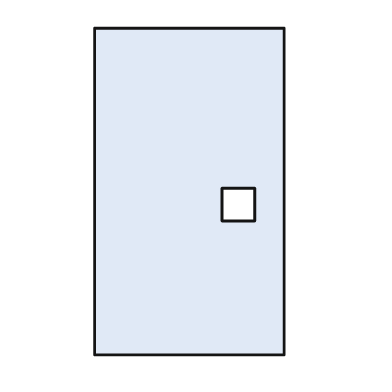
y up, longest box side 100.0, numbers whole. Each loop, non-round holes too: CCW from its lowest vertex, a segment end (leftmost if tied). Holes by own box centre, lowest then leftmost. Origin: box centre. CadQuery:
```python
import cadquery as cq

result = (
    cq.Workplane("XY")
    .moveTo(-29.0, -50.0)
    .lineTo(29.0, -50.0)
    .lineTo(29.0, 50.0)
    .lineTo(-29.0, 50.0)
    .close()
    .moveTo(10.0, -9.0)
    .lineTo(20.0, -9.0)
    .lineTo(20.0, 1.0)
    .lineTo(10.0, 1.0)
    .close()
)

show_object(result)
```